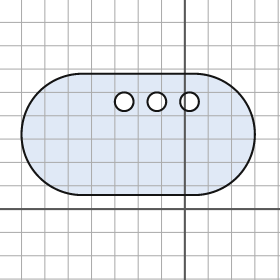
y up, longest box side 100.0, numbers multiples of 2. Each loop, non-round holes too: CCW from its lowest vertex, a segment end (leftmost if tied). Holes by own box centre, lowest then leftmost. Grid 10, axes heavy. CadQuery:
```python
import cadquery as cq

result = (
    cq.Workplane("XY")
    .moveTo(-44.0, 6.0)
    .lineTo(4.0, 6.0)
    .threePointArc((30.0, 32.0), (4.0, 58.0))
    .lineTo(-44.0, 58.0)
    .threePointArc((-70.0, 32.0), (-44.0, 6.0))
    .close()
    .moveTo(-26.0, 46.0)
    .circle(4.0)
    .moveTo(-12.0, 46.0)
    .circle(4.0)
    .moveTo(2.0, 46.0)
    .circle(4.0)
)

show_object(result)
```